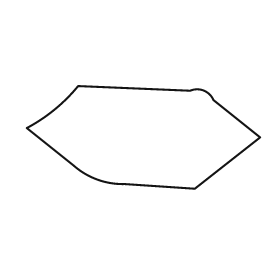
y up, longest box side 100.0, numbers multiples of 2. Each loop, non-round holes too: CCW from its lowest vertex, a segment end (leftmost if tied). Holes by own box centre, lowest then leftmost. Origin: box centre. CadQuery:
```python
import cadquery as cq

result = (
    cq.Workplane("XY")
    .moveTo(22.0, -22.0)
    .lineTo(50.0, 0.0)
    .lineTo(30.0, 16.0)
    .threePointArc((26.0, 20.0), (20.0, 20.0))
    .lineTo(-28.0, 22.0)
    .threePointArc((-38.0, 12.0), (-50.0, 4.0))
    .lineTo(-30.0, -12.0)
    .threePointArc((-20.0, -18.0), (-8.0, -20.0))
    .close()
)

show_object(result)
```